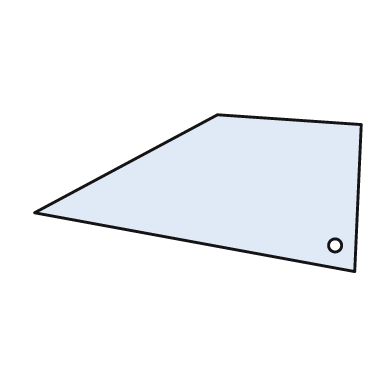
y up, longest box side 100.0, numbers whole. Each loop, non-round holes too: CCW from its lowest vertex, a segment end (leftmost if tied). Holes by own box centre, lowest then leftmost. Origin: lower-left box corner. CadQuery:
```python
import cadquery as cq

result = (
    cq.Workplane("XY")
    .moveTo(98.0, 0.0)
    .lineTo(100.0, 45.0)
    .lineTo(56.0, 48.0)
    .lineTo(0.0, 18.0)
    .close()
    .moveTo(92.0, 8.0)
    .circle(2.0)
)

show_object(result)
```